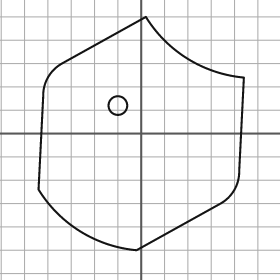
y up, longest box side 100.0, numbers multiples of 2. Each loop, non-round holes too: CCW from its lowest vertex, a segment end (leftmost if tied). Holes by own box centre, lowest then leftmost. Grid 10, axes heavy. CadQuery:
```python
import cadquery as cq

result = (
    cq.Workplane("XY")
    .moveTo(-2.0, -50.0)
    .lineTo(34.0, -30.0)
    .threePointArc((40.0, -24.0), (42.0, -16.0))
    .lineTo(44.0, 24.0)
    .threePointArc((20.0, 32.0), (2.0, 50.0))
    .lineTo(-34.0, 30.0)
    .threePointArc((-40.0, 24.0), (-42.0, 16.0))
    .lineTo(-44.0, -24.0)
    .threePointArc((-26.0, -42.0), (-2.0, -50.0))
    .close()
    .moveTo(-10.0, 12.0)
    .circle(4.0)
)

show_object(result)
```